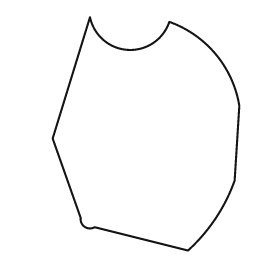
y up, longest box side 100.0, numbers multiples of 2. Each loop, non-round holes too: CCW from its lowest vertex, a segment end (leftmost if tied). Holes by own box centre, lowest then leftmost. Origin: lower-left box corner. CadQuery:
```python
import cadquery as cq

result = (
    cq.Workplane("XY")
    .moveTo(58.0, 0.0)
    .threePointArc((70.0, 14.0), (78.0, 30.0))
    .lineTo(80.0, 62.0)
    .threePointArc((70.0, 84.0), (50.0, 98.0))
    .threePointArc((32.0, 86.0), (16.0, 100.0))
    .lineTo(0.0, 48.0)
    .lineTo(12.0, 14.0)
    .threePointArc((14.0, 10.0), (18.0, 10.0))
    .close()
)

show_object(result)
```